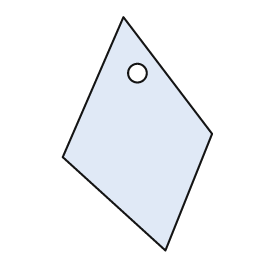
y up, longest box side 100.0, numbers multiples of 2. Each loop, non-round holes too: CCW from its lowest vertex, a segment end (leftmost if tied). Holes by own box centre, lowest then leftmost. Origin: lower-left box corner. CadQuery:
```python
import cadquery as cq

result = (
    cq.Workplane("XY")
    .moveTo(44.0, 0.0)
    .lineTo(64.0, 50.0)
    .lineTo(26.0, 100.0)
    .lineTo(0.0, 40.0)
    .close()
    .moveTo(32.0, 76.0)
    .circle(4.0)
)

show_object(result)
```